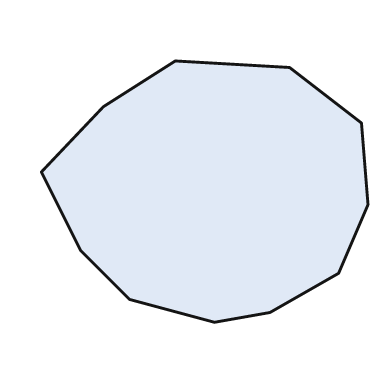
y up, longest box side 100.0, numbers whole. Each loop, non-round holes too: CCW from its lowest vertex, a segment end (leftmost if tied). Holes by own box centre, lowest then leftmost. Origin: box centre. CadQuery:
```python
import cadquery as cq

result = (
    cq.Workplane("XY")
    .moveTo(3.0, -40.0)
    .lineTo(20.0, -37.0)
    .lineTo(41.0, -25.0)
    .lineTo(50.0, -4.0)
    .lineTo(48.0, 21.0)
    .lineTo(26.0, 38.0)
    .lineTo(-9.0, 40.0)
    .lineTo(-31.0, 26.0)
    .lineTo(-50.0, 6.0)
    .lineTo(-38.0, -18.0)
    .lineTo(-23.0, -33.0)
    .close()
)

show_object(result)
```